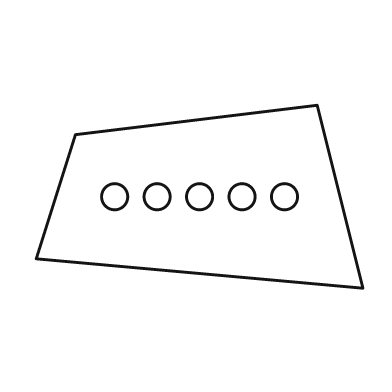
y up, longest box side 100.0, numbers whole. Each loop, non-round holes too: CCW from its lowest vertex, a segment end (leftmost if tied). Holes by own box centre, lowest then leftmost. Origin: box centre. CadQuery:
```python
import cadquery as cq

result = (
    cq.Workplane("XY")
    .moveTo(50.0, -28.0)
    .lineTo(36.0, 28.0)
    .lineTo(-38.0, 19.0)
    .lineTo(-50.0, -19.0)
    .close()
    .moveTo(-26.0, 0.0)
    .circle(4.0)
    .moveTo(-13.0, 0.0)
    .circle(4.0)
    .moveTo(0.0, 0.0)
    .circle(4.0)
    .moveTo(13.0, 0.0)
    .circle(4.0)
    .moveTo(26.0, 0.0)
    .circle(4.0)
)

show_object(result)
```